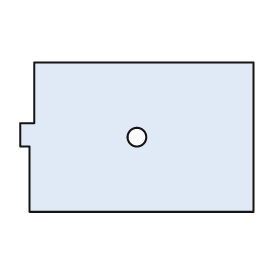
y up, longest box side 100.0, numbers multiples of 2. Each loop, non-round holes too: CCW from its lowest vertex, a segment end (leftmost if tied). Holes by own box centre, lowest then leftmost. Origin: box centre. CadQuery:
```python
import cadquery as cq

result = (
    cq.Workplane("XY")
    .moveTo(-46.0, -32.0)
    .lineTo(50.0, -32.0)
    .lineTo(50.0, 32.0)
    .lineTo(-44.0, 32.0)
    .lineTo(-44.0, 6.0)
    .lineTo(-50.0, 6.0)
    .lineTo(-50.0, -4.0)
    .lineTo(-46.0, -4.0)
    .close()
    .moveTo(0.0, 0.0)
    .circle(4.0)
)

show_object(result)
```